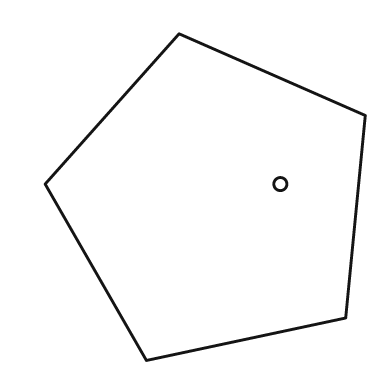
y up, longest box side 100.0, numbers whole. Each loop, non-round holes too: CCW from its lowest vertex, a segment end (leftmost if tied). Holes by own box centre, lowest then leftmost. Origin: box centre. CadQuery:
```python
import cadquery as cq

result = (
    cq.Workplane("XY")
    .moveTo(-18.0, -50.0)
    .lineTo(43.0, -37.0)
    .lineTo(49.0, 25.0)
    .lineTo(-8.0, 50.0)
    .lineTo(-49.0, 4.0)
    .close()
    .moveTo(23.0, 4.0)
    .circle(2.0)
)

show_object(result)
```